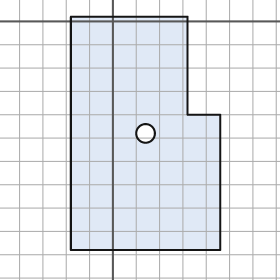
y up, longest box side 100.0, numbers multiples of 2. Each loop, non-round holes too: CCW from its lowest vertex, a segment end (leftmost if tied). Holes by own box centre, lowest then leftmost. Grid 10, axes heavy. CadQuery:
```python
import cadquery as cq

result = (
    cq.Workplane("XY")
    .moveTo(-18.0, -98.0)
    .lineTo(46.0, -98.0)
    .lineTo(46.0, -40.0)
    .lineTo(32.0, -40.0)
    .lineTo(32.0, 2.0)
    .lineTo(-18.0, 2.0)
    .close()
    .moveTo(14.0, -48.0)
    .circle(4.0)
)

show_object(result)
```